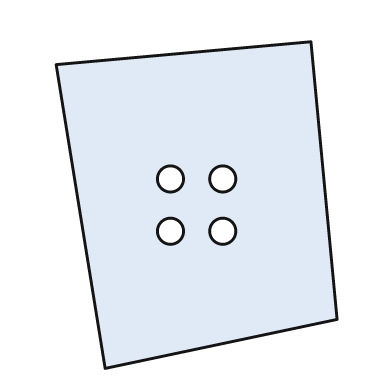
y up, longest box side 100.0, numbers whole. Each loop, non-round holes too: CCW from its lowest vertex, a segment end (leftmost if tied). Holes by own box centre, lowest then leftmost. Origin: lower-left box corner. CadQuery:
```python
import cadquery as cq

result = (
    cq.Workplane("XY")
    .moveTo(15.0, 0.0)
    .lineTo(86.0, 15.0)
    .lineTo(78.0, 100.0)
    .lineTo(0.0, 93.0)
    .close()
    .moveTo(35.0, 42.0)
    .circle(4.0)
    .moveTo(51.0, 42.0)
    .circle(4.0)
    .moveTo(35.0, 58.0)
    .circle(4.0)
    .moveTo(51.0, 58.0)
    .circle(4.0)
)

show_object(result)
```